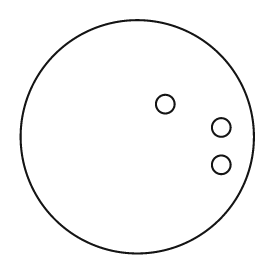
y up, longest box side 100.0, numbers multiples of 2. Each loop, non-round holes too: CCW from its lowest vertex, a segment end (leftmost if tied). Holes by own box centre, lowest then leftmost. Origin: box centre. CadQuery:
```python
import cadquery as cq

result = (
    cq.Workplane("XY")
    .moveTo(0.0, 0.0)
    .circle(50.0)
    .moveTo(36.0, -12.0)
    .circle(4.0)
    .moveTo(36.0, 4.0)
    .circle(4.0)
    .moveTo(12.0, 14.0)
    .circle(4.0)
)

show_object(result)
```